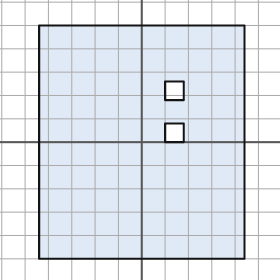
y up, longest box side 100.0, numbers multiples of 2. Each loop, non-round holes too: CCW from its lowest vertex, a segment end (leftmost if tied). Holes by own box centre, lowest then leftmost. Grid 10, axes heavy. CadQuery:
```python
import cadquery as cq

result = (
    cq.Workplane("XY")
    .moveTo(-44.0, -50.0)
    .lineTo(44.0, -50.0)
    .lineTo(44.0, 50.0)
    .lineTo(-44.0, 50.0)
    .close()
    .moveTo(10.0, 0.0)
    .lineTo(18.0, 0.0)
    .lineTo(18.0, 8.0)
    .lineTo(10.0, 8.0)
    .close()
    .moveTo(10.0, 18.0)
    .lineTo(18.0, 18.0)
    .lineTo(18.0, 26.0)
    .lineTo(10.0, 26.0)
    .close()
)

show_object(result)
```